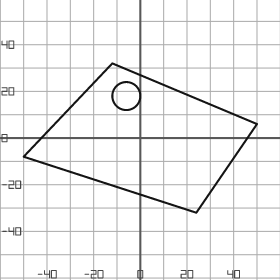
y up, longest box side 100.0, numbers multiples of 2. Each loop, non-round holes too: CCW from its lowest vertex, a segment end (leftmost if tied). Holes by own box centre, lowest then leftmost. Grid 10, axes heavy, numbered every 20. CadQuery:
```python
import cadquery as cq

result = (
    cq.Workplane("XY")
    .moveTo(24.0, -32.0)
    .lineTo(50.0, 6.0)
    .lineTo(-12.0, 32.0)
    .lineTo(-50.0, -8.0)
    .close()
    .moveTo(-6.0, 18.0)
    .circle(6.0)
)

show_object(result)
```